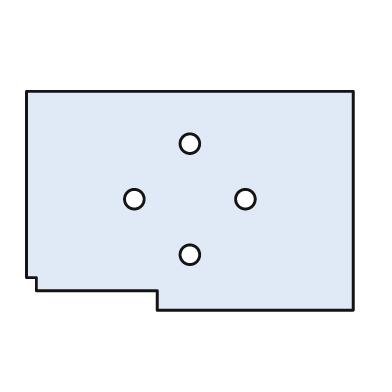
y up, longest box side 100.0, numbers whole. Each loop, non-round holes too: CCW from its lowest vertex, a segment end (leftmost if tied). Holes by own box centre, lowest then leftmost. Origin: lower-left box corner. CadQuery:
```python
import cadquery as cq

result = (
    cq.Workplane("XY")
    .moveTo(40.0, 0.0)
    .lineTo(100.0, 0.0)
    .lineTo(100.0, 67.0)
    .lineTo(0.0, 67.0)
    .lineTo(0.0, 10.0)
    .lineTo(3.0, 10.0)
    .lineTo(3.0, 6.0)
    .lineTo(40.0, 6.0)
    .close()
    .moveTo(50.0, 17.0)
    .circle(3.0)
    .moveTo(33.0, 34.0)
    .circle(3.0)
    .moveTo(67.0, 34.0)
    .circle(3.0)
    .moveTo(50.0, 51.0)
    .circle(3.0)
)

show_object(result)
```